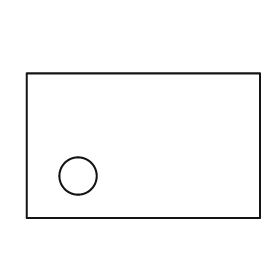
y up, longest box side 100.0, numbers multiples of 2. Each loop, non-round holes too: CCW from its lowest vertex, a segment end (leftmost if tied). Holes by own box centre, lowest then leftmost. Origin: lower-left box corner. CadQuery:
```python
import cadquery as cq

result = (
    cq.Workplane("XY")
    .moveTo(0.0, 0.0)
    .lineTo(100.0, 0.0)
    .lineTo(100.0, 62.0)
    .lineTo(0.0, 62.0)
    .close()
    .moveTo(22.0, 18.0)
    .circle(8.0)
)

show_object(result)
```